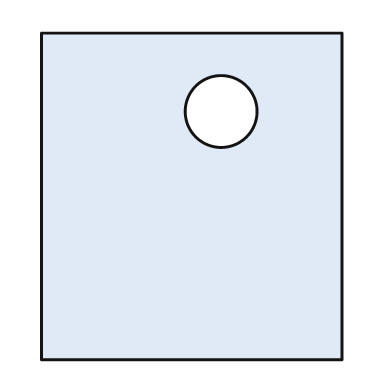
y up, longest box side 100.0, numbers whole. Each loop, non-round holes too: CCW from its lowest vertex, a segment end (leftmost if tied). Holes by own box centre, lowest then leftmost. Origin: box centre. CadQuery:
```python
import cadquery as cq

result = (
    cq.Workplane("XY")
    .moveTo(-46.0, -50.0)
    .lineTo(46.0, -50.0)
    .lineTo(46.0, 50.0)
    .lineTo(-46.0, 50.0)
    .close()
    .moveTo(9.0, 26.0)
    .circle(11.0)
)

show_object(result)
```